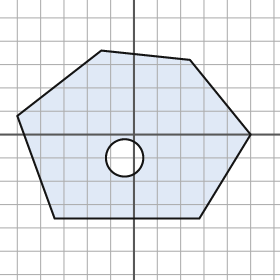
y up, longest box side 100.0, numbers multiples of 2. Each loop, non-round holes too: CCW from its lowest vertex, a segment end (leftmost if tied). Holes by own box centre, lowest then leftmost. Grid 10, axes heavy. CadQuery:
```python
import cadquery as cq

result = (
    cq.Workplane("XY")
    .moveTo(-34.0, -36.0)
    .lineTo(28.0, -36.0)
    .lineTo(50.0, 0.0)
    .lineTo(24.0, 32.0)
    .lineTo(-14.0, 36.0)
    .lineTo(-50.0, 8.0)
    .close()
    .moveTo(-4.0, -10.0)
    .circle(8.0)
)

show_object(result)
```